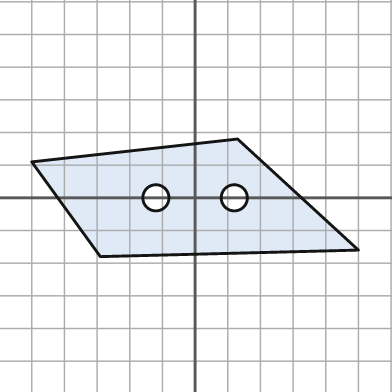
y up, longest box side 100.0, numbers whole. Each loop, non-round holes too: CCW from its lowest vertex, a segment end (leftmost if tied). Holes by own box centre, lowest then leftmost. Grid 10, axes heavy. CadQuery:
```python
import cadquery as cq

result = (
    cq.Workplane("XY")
    .moveTo(-29.0, -18.0)
    .lineTo(50.0, -16.0)
    .lineTo(13.0, 18.0)
    .lineTo(-50.0, 11.0)
    .close()
    .moveTo(-12.0, 0.0)
    .circle(4.0)
    .moveTo(12.0, 0.0)
    .circle(4.0)
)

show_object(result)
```